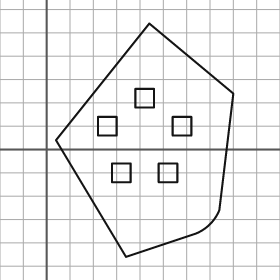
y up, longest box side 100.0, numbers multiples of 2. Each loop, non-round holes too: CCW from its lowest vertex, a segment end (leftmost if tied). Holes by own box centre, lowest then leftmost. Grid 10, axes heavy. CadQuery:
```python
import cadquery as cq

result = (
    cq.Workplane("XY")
    .moveTo(34.0, -46.0)
    .lineTo(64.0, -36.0)
    .threePointArc((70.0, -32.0), (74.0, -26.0))
    .lineTo(80.0, 24.0)
    .lineTo(44.0, 54.0)
    .lineTo(4.0, 4.0)
    .close()
    .moveTo(28.0, -14.0)
    .lineTo(36.0, -14.0)
    .lineTo(36.0, -6.0)
    .lineTo(28.0, -6.0)
    .close()
    .moveTo(48.0, -14.0)
    .lineTo(56.0, -14.0)
    .lineTo(56.0, -6.0)
    .lineTo(48.0, -6.0)
    .close()
    .moveTo(22.0, 6.0)
    .lineTo(30.0, 6.0)
    .lineTo(30.0, 14.0)
    .lineTo(22.0, 14.0)
    .close()
    .moveTo(54.0, 6.0)
    .lineTo(62.0, 6.0)
    .lineTo(62.0, 14.0)
    .lineTo(54.0, 14.0)
    .close()
    .moveTo(38.0, 18.0)
    .lineTo(46.0, 18.0)
    .lineTo(46.0, 26.0)
    .lineTo(38.0, 26.0)
    .close()
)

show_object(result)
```